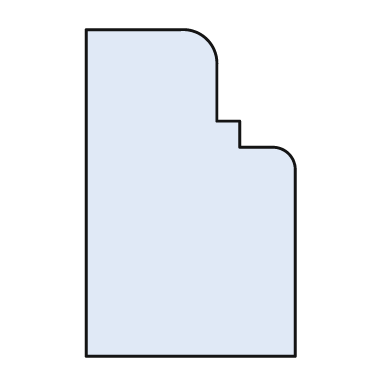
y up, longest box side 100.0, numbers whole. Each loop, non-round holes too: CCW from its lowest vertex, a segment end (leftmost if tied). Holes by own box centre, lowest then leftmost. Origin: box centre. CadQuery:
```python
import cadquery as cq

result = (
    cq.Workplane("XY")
    .moveTo(-32.0, -50.0)
    .lineTo(32.0, -50.0)
    .lineTo(32.0, 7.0)
    .threePointArc((30.0, 12.0), (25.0, 14.0))
    .lineTo(15.0, 14.0)
    .lineTo(15.0, 22.0)
    .lineTo(8.0, 22.0)
    .lineTo(8.0, 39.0)
    .threePointArc((5.0, 47.0), (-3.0, 50.0))
    .lineTo(-32.0, 50.0)
    .close()
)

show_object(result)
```